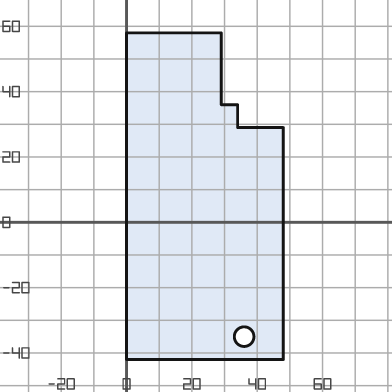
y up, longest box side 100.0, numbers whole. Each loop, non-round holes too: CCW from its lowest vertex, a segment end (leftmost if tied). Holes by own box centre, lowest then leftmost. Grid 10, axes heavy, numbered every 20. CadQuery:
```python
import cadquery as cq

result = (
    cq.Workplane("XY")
    .moveTo(0.0, -42.0)
    .lineTo(48.0, -42.0)
    .lineTo(48.0, 29.0)
    .lineTo(34.0, 29.0)
    .lineTo(34.0, 36.0)
    .lineTo(29.0, 36.0)
    .lineTo(29.0, 58.0)
    .lineTo(0.0, 58.0)
    .close()
    .moveTo(36.0, -35.0)
    .circle(3.0)
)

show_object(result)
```